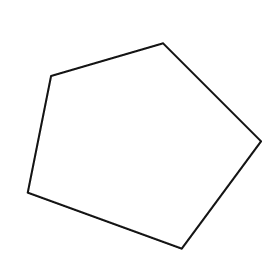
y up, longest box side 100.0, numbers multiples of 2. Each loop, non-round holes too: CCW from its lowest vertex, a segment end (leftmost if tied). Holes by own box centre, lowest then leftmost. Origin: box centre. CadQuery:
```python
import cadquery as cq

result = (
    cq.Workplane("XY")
    .moveTo(16.0, -44.0)
    .lineTo(50.0, 2.0)
    .lineTo(8.0, 44.0)
    .lineTo(-40.0, 30.0)
    .lineTo(-50.0, -20.0)
    .close()
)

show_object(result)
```